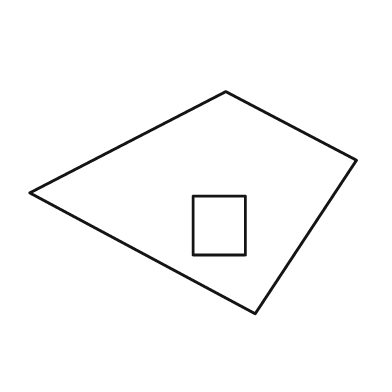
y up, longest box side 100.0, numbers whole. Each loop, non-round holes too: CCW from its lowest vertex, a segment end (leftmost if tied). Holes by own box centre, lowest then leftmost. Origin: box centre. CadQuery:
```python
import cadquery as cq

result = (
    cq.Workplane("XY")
    .moveTo(19.0, -34.0)
    .lineTo(50.0, 13.0)
    .lineTo(10.0, 34.0)
    .lineTo(-50.0, 3.0)
    .close()
    .moveTo(0.0, -16.0)
    .lineTo(16.0, -16.0)
    .lineTo(16.0, 2.0)
    .lineTo(0.0, 2.0)
    .close()
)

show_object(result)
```